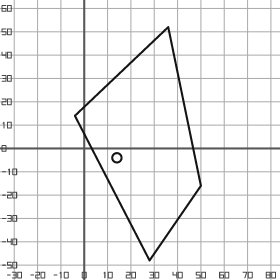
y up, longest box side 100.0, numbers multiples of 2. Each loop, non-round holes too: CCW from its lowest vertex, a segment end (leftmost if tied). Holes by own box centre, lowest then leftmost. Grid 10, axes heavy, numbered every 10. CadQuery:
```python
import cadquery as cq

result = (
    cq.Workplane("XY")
    .moveTo(28.0, -48.0)
    .lineTo(50.0, -16.0)
    .lineTo(36.0, 52.0)
    .lineTo(-4.0, 14.0)
    .close()
    .moveTo(14.0, -4.0)
    .circle(2.0)
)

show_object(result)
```